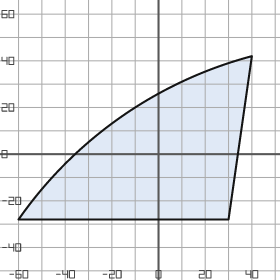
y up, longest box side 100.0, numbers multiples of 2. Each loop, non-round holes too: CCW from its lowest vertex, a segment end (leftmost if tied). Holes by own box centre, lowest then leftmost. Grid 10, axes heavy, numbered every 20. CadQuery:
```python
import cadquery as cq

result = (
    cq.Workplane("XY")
    .moveTo(-60.0, -28.0)
    .lineTo(30.0, -28.0)
    .lineTo(40.0, 42.0)
    .threePointArc((-16.0, 16.0), (-60.0, -28.0))
    .close()
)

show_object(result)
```